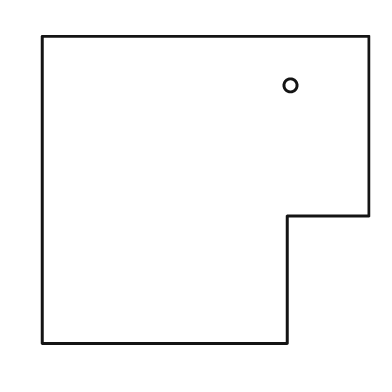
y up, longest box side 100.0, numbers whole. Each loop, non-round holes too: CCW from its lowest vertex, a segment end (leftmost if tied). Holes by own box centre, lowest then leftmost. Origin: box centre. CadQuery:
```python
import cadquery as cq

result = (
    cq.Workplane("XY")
    .moveTo(-50.0, -47.0)
    .lineTo(25.0, -47.0)
    .lineTo(25.0, -8.0)
    .lineTo(50.0, -8.0)
    .lineTo(50.0, 47.0)
    .lineTo(-50.0, 47.0)
    .close()
    .moveTo(26.0, 32.0)
    .circle(2.0)
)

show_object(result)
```